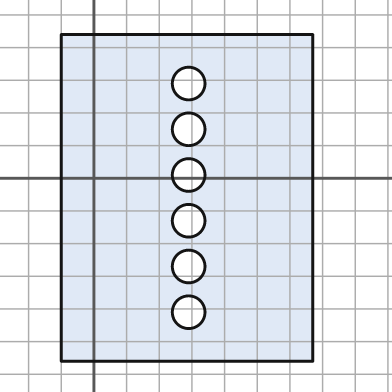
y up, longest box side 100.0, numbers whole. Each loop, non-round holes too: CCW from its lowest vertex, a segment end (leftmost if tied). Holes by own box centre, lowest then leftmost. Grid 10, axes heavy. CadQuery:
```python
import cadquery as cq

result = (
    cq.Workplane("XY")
    .moveTo(-10.0, -56.0)
    .lineTo(67.0, -56.0)
    .lineTo(67.0, 44.0)
    .lineTo(-10.0, 44.0)
    .close()
    .moveTo(29.0, -41.0)
    .circle(5.0)
    .moveTo(29.0, -27.0)
    .circle(5.0)
    .moveTo(29.0, -13.0)
    .circle(5.0)
    .moveTo(29.0, 1.0)
    .circle(5.0)
    .moveTo(29.0, 15.0)
    .circle(5.0)
    .moveTo(29.0, 29.0)
    .circle(5.0)
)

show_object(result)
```